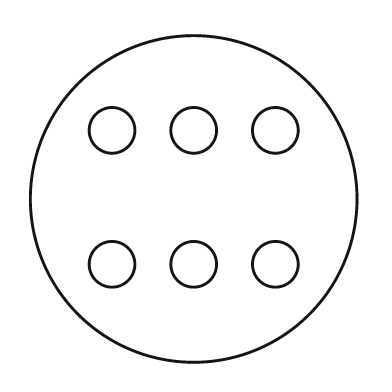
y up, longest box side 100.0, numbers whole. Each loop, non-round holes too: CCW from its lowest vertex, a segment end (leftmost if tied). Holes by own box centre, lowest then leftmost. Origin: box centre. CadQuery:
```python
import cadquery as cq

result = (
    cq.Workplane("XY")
    .moveTo(0.0, 0.0)
    .circle(50.0)
    .moveTo(-25.0, -20.0)
    .circle(7.0)
    .moveTo(0.0, -20.0)
    .circle(7.0)
    .moveTo(25.0, -20.0)
    .circle(7.0)
    .moveTo(-25.0, 21.0)
    .circle(7.0)
    .moveTo(0.0, 21.0)
    .circle(7.0)
    .moveTo(25.0, 21.0)
    .circle(7.0)
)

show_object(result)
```